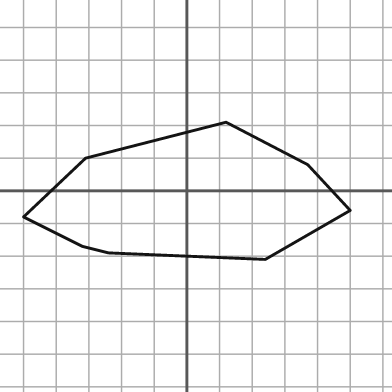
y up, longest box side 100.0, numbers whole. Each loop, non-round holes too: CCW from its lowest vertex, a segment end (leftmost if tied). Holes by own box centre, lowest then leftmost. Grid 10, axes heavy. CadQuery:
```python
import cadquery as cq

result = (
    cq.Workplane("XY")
    .moveTo(24.0, -21.0)
    .lineTo(50.0, -6.0)
    .lineTo(37.0, 8.0)
    .lineTo(12.0, 21.0)
    .lineTo(-31.0, 10.0)
    .lineTo(-50.0, -8.0)
    .lineTo(-32.0, -17.0)
    .lineTo(-24.0, -19.0)
    .close()
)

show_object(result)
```